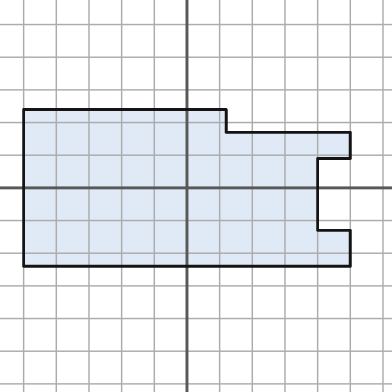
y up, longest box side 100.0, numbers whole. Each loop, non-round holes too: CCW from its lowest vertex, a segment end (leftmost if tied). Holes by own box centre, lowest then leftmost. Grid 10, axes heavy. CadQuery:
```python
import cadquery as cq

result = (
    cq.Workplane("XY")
    .moveTo(-50.0, -24.0)
    .lineTo(50.0, -24.0)
    .lineTo(50.0, -13.0)
    .lineTo(40.0, -13.0)
    .lineTo(40.0, 9.0)
    .lineTo(50.0, 9.0)
    .lineTo(50.0, 17.0)
    .lineTo(12.0, 17.0)
    .lineTo(12.0, 24.0)
    .lineTo(-50.0, 24.0)
    .close()
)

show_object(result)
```